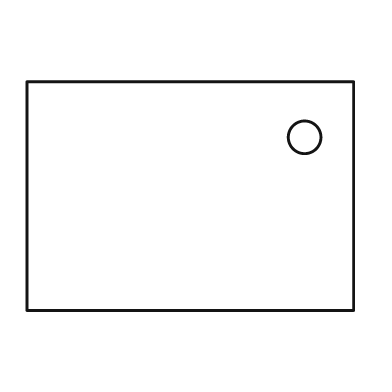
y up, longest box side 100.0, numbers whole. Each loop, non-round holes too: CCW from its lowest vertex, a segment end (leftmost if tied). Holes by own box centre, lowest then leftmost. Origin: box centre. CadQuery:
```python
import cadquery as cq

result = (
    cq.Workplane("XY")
    .moveTo(-50.0, -35.0)
    .lineTo(50.0, -35.0)
    .lineTo(50.0, 35.0)
    .lineTo(-50.0, 35.0)
    .close()
    .moveTo(35.0, 18.0)
    .circle(5.0)
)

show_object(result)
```